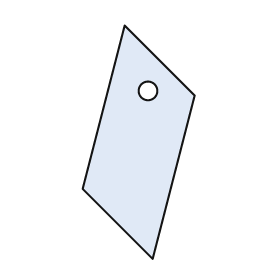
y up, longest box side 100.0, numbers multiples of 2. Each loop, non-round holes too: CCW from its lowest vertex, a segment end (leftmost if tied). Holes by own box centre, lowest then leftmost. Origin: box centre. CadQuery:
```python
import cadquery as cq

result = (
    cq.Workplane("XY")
    .moveTo(6.0, -50.0)
    .lineTo(24.0, 20.0)
    .lineTo(-6.0, 50.0)
    .lineTo(-24.0, -20.0)
    .close()
    .moveTo(4.0, 22.0)
    .circle(4.0)
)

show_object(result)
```